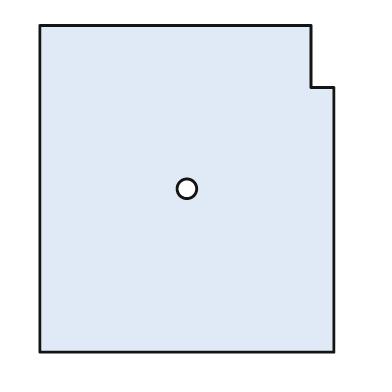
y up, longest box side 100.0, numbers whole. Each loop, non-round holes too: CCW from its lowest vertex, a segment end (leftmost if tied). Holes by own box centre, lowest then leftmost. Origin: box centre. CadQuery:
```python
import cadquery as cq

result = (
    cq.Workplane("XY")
    .moveTo(-45.0, -50.0)
    .lineTo(45.0, -50.0)
    .lineTo(45.0, 31.0)
    .lineTo(38.0, 31.0)
    .lineTo(38.0, 50.0)
    .lineTo(-45.0, 50.0)
    .close()
    .moveTo(0.0, 0.0)
    .circle(3.0)
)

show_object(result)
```